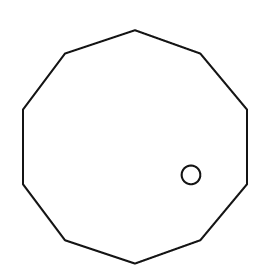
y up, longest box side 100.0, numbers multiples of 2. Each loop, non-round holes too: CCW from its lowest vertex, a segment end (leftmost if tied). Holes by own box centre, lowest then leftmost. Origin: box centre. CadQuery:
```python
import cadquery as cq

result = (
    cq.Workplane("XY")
    .moveTo(0.0, -50.0)
    .lineTo(28.0, -40.0)
    .lineTo(48.0, -16.0)
    .lineTo(48.0, 16.0)
    .lineTo(28.0, 40.0)
    .lineTo(0.0, 50.0)
    .lineTo(-30.0, 40.0)
    .lineTo(-48.0, 16.0)
    .lineTo(-48.0, -16.0)
    .lineTo(-30.0, -40.0)
    .close()
    .moveTo(24.0, -12.0)
    .circle(4.0)
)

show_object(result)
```